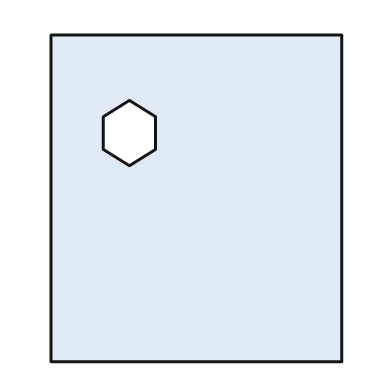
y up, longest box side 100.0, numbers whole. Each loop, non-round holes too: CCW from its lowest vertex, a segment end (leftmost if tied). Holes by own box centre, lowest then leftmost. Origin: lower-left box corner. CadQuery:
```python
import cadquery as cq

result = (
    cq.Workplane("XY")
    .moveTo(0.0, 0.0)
    .lineTo(89.0, 0.0)
    .lineTo(89.0, 100.0)
    .lineTo(0.0, 100.0)
    .close()
    .moveTo(24.0, 60.0)
    .lineTo(32.0, 65.0)
    .lineTo(32.0, 75.0)
    .lineTo(24.0, 80.0)
    .lineTo(16.0, 75.0)
    .lineTo(16.0, 65.0)
    .close()
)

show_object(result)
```